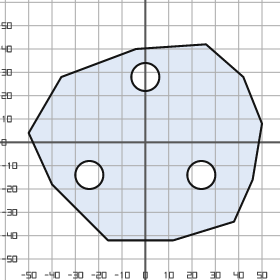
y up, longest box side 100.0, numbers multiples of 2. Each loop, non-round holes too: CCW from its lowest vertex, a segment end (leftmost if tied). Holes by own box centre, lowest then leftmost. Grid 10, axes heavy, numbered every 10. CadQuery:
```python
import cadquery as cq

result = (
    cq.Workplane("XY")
    .moveTo(-16.0, -42.0)
    .lineTo(12.0, -42.0)
    .lineTo(38.0, -34.0)
    .lineTo(46.0, -16.0)
    .lineTo(50.0, 8.0)
    .lineTo(42.0, 28.0)
    .lineTo(26.0, 42.0)
    .lineTo(-4.0, 40.0)
    .lineTo(-36.0, 28.0)
    .lineTo(-50.0, 4.0)
    .lineTo(-40.0, -18.0)
    .close()
    .moveTo(-24.0, -14.0)
    .circle(6.0)
    .moveTo(24.0, -14.0)
    .circle(6.0)
    .moveTo(0.0, 28.0)
    .circle(6.0)
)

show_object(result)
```